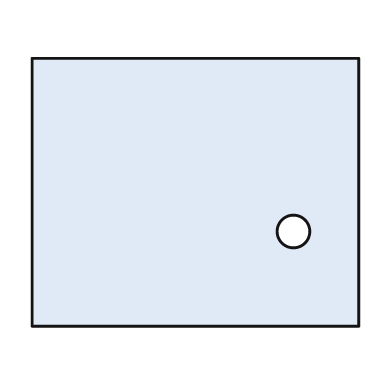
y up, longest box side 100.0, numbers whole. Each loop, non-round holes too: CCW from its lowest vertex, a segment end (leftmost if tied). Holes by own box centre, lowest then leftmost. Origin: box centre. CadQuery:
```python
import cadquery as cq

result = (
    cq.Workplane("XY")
    .moveTo(-50.0, -41.0)
    .lineTo(50.0, -41.0)
    .lineTo(50.0, 41.0)
    .lineTo(-50.0, 41.0)
    .close()
    .moveTo(30.0, -12.0)
    .circle(5.0)
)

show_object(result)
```